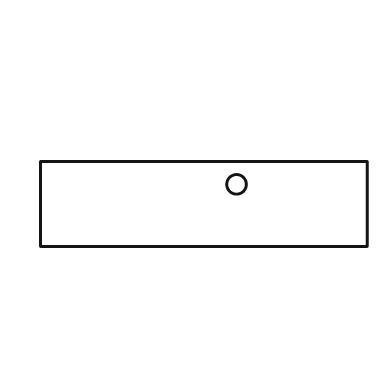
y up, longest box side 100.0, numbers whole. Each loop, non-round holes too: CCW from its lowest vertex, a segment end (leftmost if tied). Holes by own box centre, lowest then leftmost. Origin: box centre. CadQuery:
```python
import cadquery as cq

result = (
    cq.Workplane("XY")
    .moveTo(-50.0, -13.0)
    .lineTo(50.0, -13.0)
    .lineTo(50.0, 13.0)
    .lineTo(-50.0, 13.0)
    .close()
    .moveTo(10.0, 6.0)
    .circle(3.0)
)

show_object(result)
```